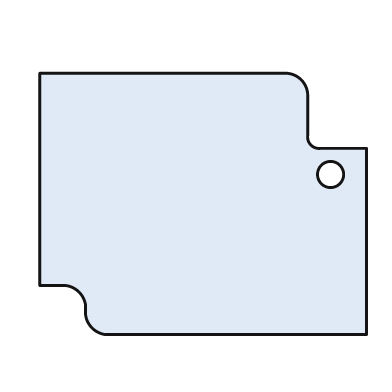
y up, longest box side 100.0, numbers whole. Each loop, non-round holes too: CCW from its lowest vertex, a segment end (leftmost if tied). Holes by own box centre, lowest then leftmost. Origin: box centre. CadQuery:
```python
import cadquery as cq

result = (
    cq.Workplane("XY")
    .moveTo(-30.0, -40.0)
    .lineTo(50.0, -40.0)
    .lineTo(50.0, 17.0)
    .lineTo(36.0, 17.0)
    .threePointArc((33.0, 18.0), (32.0, 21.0))
    .lineTo(32.0, 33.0)
    .threePointArc((30.0, 38.0), (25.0, 40.0))
    .lineTo(-50.0, 40.0)
    .lineTo(-50.0, -25.0)
    .lineTo(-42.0, -25.0)
    .threePointArc((-38.0, -27.0), (-36.0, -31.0))
    .lineTo(-36.0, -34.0)
    .threePointArc((-34.0, -38.0), (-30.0, -40.0))
    .close()
    .moveTo(39.0, 9.0)
    .circle(4.0)
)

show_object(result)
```